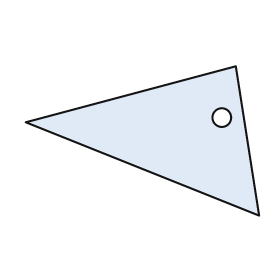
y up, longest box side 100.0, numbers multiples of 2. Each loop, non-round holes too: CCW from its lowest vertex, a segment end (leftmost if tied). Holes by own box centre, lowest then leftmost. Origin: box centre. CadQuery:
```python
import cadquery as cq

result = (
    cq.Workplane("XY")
    .moveTo(50.0, -32.0)
    .lineTo(40.0, 32.0)
    .lineTo(-50.0, 8.0)
    .close()
    .moveTo(34.0, 10.0)
    .circle(4.0)
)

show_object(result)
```